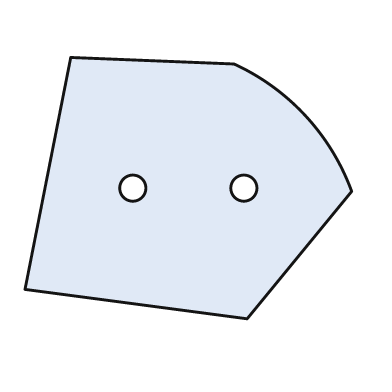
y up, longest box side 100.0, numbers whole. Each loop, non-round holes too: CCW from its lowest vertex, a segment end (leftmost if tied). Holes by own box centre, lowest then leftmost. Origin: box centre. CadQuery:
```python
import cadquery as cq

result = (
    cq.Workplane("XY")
    .moveTo(18.0, -40.0)
    .lineTo(50.0, -1.0)
    .threePointArc((36.0, 22.0), (14.0, 38.0))
    .lineTo(-36.0, 40.0)
    .lineTo(-50.0, -31.0)
    .close()
    .moveTo(-17.0, 0.0)
    .circle(4.0)
    .moveTo(17.0, 0.0)
    .circle(4.0)
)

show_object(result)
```